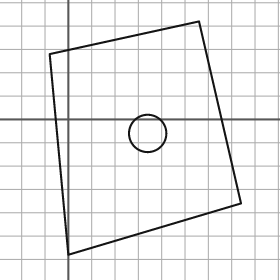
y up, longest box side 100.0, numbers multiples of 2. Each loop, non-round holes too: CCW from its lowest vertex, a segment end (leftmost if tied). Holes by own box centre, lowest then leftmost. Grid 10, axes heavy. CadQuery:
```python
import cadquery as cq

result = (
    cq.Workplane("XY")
    .moveTo(0.0, -58.0)
    .lineTo(74.0, -36.0)
    .lineTo(56.0, 42.0)
    .lineTo(-8.0, 28.0)
    .close()
    .moveTo(34.0, -6.0)
    .circle(8.0)
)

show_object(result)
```